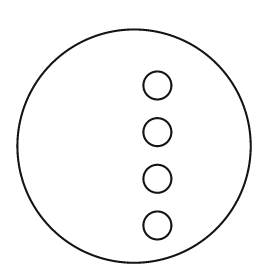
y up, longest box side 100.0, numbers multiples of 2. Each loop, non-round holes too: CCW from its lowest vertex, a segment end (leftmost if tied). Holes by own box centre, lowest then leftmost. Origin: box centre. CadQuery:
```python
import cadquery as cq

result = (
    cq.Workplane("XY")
    .moveTo(0.0, 0.0)
    .circle(50.0)
    .moveTo(10.0, -34.0)
    .circle(6.0)
    .moveTo(10.0, -14.0)
    .circle(6.0)
    .moveTo(10.0, 6.0)
    .circle(6.0)
    .moveTo(10.0, 26.0)
    .circle(6.0)
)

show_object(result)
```